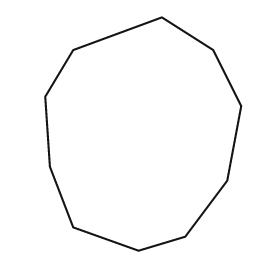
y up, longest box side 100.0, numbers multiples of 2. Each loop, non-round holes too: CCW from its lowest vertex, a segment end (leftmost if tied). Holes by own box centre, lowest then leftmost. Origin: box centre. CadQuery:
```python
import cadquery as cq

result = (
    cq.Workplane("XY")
    .moveTo(-2.0, -50.0)
    .lineTo(18.0, -44.0)
    .lineTo(36.0, -20.0)
    .lineTo(42.0, 12.0)
    .lineTo(30.0, 36.0)
    .lineTo(8.0, 50.0)
    .lineTo(-30.0, 36.0)
    .lineTo(-42.0, 16.0)
    .lineTo(-40.0, -14.0)
    .lineTo(-30.0, -40.0)
    .close()
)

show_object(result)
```